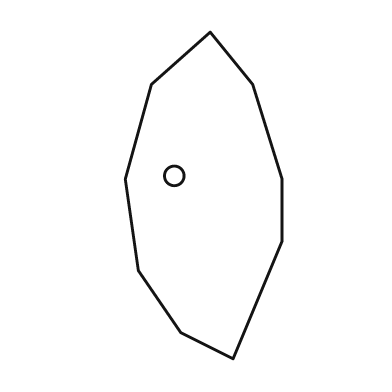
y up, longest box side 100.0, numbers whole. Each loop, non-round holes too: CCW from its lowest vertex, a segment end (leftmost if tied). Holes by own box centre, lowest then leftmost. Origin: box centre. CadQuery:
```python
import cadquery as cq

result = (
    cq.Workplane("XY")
    .moveTo(9.0, -50.0)
    .lineTo(24.0, -14.0)
    .lineTo(24.0, 5.0)
    .lineTo(15.0, 34.0)
    .lineTo(2.0, 50.0)
    .lineTo(-16.0, 34.0)
    .lineTo(-24.0, 5.0)
    .lineTo(-20.0, -23.0)
    .lineTo(-7.0, -42.0)
    .close()
    .moveTo(-9.0, 6.0)
    .circle(3.0)
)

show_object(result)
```